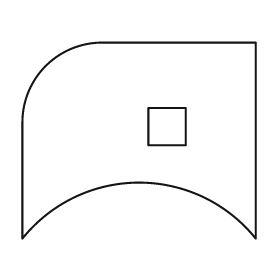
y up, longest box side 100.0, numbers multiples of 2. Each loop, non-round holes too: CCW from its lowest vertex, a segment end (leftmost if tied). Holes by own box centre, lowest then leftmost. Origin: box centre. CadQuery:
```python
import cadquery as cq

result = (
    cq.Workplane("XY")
    .moveTo(-50.0, -42.0)
    .threePointArc((0.0, -18.0), (50.0, -42.0))
    .lineTo(50.0, 42.0)
    .lineTo(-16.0, 42.0)
    .threePointArc((-40.0, 32.0), (-50.0, 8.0))
    .close()
    .moveTo(4.0, -2.0)
    .lineTo(20.0, -2.0)
    .lineTo(20.0, 14.0)
    .lineTo(4.0, 14.0)
    .close()
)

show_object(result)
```